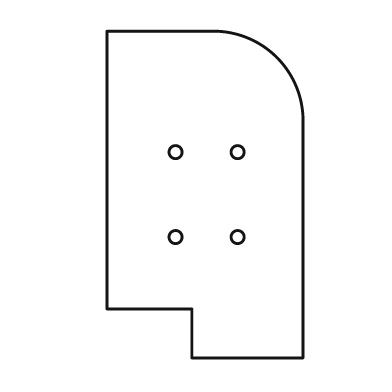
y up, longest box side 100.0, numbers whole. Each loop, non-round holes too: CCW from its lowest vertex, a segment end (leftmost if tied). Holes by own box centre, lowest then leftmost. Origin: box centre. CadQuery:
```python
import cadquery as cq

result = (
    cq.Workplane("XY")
    .moveTo(-4.0, -50.0)
    .lineTo(30.0, -50.0)
    .lineTo(30.0, 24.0)
    .threePointArc((22.0, 42.0), (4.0, 50.0))
    .lineTo(-30.0, 50.0)
    .lineTo(-30.0, -35.0)
    .lineTo(-4.0, -35.0)
    .close()
    .moveTo(-9.0, -13.0)
    .circle(2.0)
    .moveTo(10.0, -13.0)
    .circle(2.0)
    .moveTo(-9.0, 13.0)
    .circle(2.0)
    .moveTo(10.0, 13.0)
    .circle(2.0)
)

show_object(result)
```